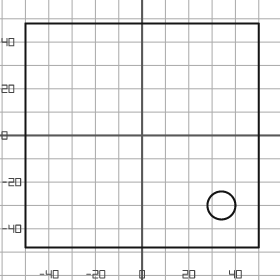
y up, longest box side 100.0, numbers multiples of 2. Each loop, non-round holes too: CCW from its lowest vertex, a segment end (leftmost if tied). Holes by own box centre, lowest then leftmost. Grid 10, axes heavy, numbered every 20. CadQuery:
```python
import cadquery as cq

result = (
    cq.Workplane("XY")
    .moveTo(-50.0, -48.0)
    .lineTo(50.0, -48.0)
    .lineTo(50.0, 48.0)
    .lineTo(-50.0, 48.0)
    .close()
    .moveTo(34.0, -30.0)
    .circle(6.0)
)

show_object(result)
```